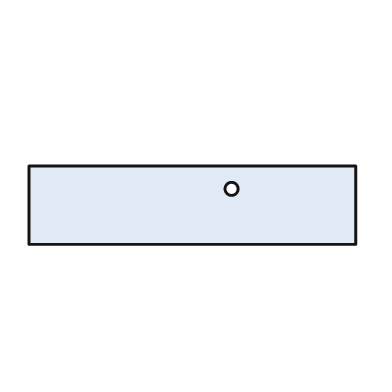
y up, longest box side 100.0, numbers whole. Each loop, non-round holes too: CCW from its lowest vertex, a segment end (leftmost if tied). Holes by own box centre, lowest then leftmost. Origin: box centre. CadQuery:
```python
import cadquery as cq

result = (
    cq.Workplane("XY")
    .moveTo(-50.0, -12.0)
    .lineTo(50.0, -12.0)
    .lineTo(50.0, 12.0)
    .lineTo(-50.0, 12.0)
    .close()
    .moveTo(12.0, 5.0)
    .circle(2.0)
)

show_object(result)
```